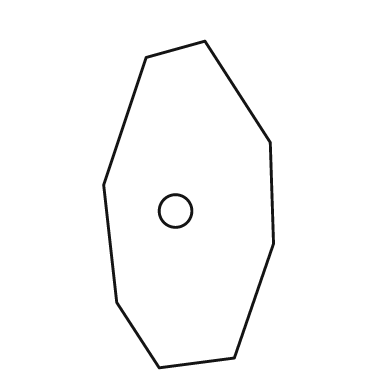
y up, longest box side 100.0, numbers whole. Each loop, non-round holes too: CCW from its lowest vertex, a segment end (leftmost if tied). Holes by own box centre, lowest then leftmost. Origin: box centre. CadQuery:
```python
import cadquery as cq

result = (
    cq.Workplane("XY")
    .moveTo(-9.0, -50.0)
    .lineTo(14.0, -47.0)
    .lineTo(26.0, -12.0)
    .lineTo(25.0, 19.0)
    .lineTo(5.0, 50.0)
    .lineTo(-13.0, 45.0)
    .lineTo(-26.0, 6.0)
    .lineTo(-22.0, -30.0)
    .close()
    .moveTo(-4.0, -2.0)
    .circle(5.0)
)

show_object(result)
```